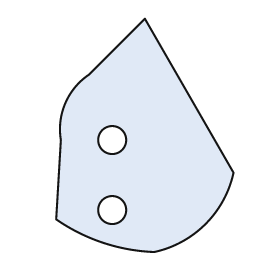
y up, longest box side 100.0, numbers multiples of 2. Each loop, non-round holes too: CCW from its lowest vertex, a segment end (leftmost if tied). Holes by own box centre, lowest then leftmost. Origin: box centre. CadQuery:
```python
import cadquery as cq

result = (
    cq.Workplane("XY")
    .moveTo(4.0, -50.0)
    .threePointArc((26.0, -38.0), (38.0, -16.0))
    .lineTo(0.0, 50.0)
    .lineTo(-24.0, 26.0)
    .threePointArc((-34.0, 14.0), (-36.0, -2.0))
    .lineTo(-38.0, -36.0)
    .threePointArc((-18.0, -46.0), (4.0, -50.0))
    .close()
    .moveTo(-14.0, -32.0)
    .circle(6.0)
    .moveTo(-14.0, -2.0)
    .circle(6.0)
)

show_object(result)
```